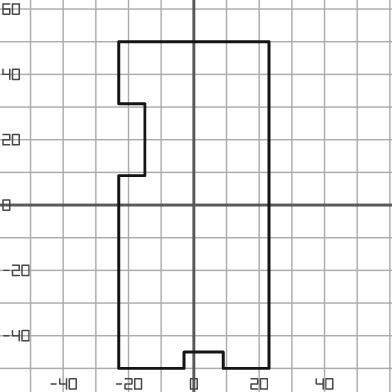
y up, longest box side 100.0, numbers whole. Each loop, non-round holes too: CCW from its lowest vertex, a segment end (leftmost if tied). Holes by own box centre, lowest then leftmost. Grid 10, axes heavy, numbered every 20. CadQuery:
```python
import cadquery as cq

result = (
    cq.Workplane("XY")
    .moveTo(-23.0, -50.0)
    .lineTo(-3.0, -50.0)
    .lineTo(-3.0, -45.0)
    .lineTo(9.0, -45.0)
    .lineTo(9.0, -50.0)
    .lineTo(23.0, -50.0)
    .lineTo(23.0, 50.0)
    .lineTo(-23.0, 50.0)
    .lineTo(-23.0, 31.0)
    .lineTo(-15.0, 31.0)
    .lineTo(-15.0, 9.0)
    .lineTo(-23.0, 9.0)
    .close()
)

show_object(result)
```